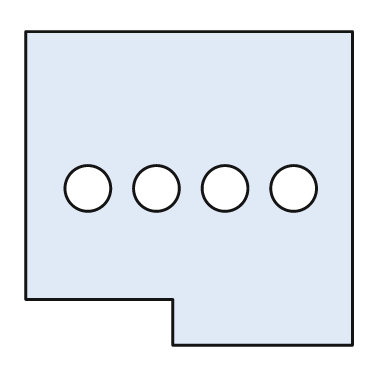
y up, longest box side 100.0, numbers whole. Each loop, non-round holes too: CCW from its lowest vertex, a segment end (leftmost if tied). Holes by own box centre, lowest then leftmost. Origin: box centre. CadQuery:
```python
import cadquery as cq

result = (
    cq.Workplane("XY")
    .moveTo(-5.0, -48.0)
    .lineTo(50.0, -48.0)
    .lineTo(50.0, 48.0)
    .lineTo(-50.0, 48.0)
    .lineTo(-50.0, -34.0)
    .lineTo(-5.0, -34.0)
    .close()
    .moveTo(-31.0, 0.0)
    .circle(7.0)
    .moveTo(-10.0, 0.0)
    .circle(7.0)
    .moveTo(11.0, 0.0)
    .circle(7.0)
    .moveTo(32.0, 0.0)
    .circle(7.0)
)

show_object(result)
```